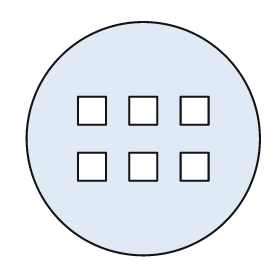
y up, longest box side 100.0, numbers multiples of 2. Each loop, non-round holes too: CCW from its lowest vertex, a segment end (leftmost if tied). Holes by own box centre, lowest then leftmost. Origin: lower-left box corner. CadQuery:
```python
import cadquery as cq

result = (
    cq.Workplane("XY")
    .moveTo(50.0, 50.0)
    .circle(50.0)
    .moveTo(22.0, 32.0)
    .lineTo(34.0, 32.0)
    .lineTo(34.0, 44.0)
    .lineTo(22.0, 44.0)
    .close()
    .moveTo(44.0, 32.0)
    .lineTo(56.0, 32.0)
    .lineTo(56.0, 44.0)
    .lineTo(44.0, 44.0)
    .close()
    .moveTo(66.0, 32.0)
    .lineTo(78.0, 32.0)
    .lineTo(78.0, 44.0)
    .lineTo(66.0, 44.0)
    .close()
    .moveTo(22.0, 56.0)
    .lineTo(34.0, 56.0)
    .lineTo(34.0, 68.0)
    .lineTo(22.0, 68.0)
    .close()
    .moveTo(44.0, 56.0)
    .lineTo(56.0, 56.0)
    .lineTo(56.0, 68.0)
    .lineTo(44.0, 68.0)
    .close()
    .moveTo(66.0, 56.0)
    .lineTo(78.0, 56.0)
    .lineTo(78.0, 68.0)
    .lineTo(66.0, 68.0)
    .close()
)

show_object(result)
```